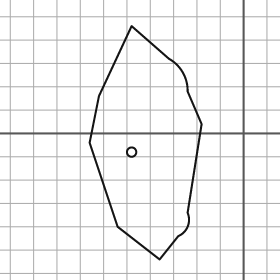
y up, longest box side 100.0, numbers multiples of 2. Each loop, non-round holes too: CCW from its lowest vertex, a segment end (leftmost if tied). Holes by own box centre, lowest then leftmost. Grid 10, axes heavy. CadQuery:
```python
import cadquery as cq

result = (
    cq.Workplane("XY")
    .moveTo(-36.0, -54.0)
    .lineTo(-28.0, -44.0)
    .threePointArc((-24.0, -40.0), (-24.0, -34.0))
    .lineTo(-18.0, 4.0)
    .lineTo(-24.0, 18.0)
    .threePointArc((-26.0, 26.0), (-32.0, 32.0))
    .lineTo(-48.0, 46.0)
    .lineTo(-62.0, 16.0)
    .lineTo(-66.0, -4.0)
    .lineTo(-54.0, -40.0)
    .close()
    .moveTo(-48.0, -8.0)
    .circle(2.0)
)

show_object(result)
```